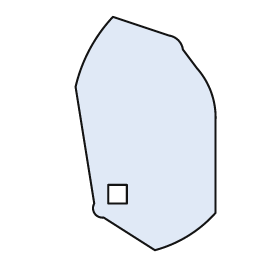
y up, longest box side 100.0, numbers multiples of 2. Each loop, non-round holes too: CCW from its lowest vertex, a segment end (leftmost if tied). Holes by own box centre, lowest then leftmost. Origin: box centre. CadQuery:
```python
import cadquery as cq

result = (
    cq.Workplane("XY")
    .moveTo(4.0, -50.0)
    .threePointArc((18.0, -44.0), (30.0, -34.0))
    .lineTo(30.0, 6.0)
    .threePointArc((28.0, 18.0), (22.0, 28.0))
    .lineTo(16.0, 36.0)
    .threePointArc((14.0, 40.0), (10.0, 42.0))
    .lineTo(-14.0, 50.0)
    .threePointArc((-24.0, 36.0), (-30.0, 20.0))
    .lineTo(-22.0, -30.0)
    .threePointArc((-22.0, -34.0), (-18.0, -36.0))
    .close()
    .moveTo(-16.0, -30.0)
    .lineTo(-8.0, -30.0)
    .lineTo(-8.0, -22.0)
    .lineTo(-16.0, -22.0)
    .close()
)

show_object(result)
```